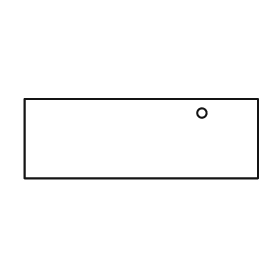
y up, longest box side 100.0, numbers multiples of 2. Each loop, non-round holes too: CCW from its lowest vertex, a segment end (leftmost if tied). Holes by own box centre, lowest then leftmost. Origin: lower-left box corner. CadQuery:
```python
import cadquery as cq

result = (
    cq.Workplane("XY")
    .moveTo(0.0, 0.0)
    .lineTo(100.0, 0.0)
    .lineTo(100.0, 34.0)
    .lineTo(0.0, 34.0)
    .close()
    .moveTo(76.0, 28.0)
    .circle(2.0)
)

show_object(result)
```